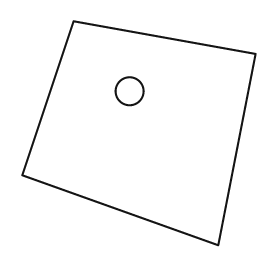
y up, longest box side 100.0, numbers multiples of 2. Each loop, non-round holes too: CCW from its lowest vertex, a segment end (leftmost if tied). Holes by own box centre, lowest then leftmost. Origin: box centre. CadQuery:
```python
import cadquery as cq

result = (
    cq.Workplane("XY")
    .moveTo(34.0, -48.0)
    .lineTo(50.0, 34.0)
    .lineTo(-28.0, 48.0)
    .lineTo(-50.0, -18.0)
    .close()
    .moveTo(-4.0, 18.0)
    .circle(6.0)
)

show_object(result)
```